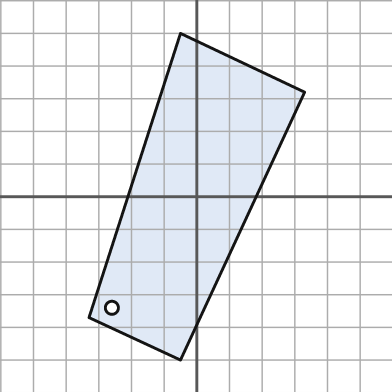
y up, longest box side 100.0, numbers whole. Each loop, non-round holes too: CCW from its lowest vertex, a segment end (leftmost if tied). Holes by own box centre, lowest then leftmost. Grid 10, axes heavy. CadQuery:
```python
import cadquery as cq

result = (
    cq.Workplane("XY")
    .moveTo(-5.0, -50.0)
    .lineTo(33.0, 32.0)
    .lineTo(-5.0, 50.0)
    .lineTo(-33.0, -37.0)
    .close()
    .moveTo(-26.0, -34.0)
    .circle(2.0)
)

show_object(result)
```